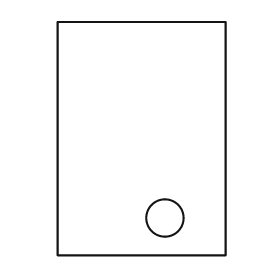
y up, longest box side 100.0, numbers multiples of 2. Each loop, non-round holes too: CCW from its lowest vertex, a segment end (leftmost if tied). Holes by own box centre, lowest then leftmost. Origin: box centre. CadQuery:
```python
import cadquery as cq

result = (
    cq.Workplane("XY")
    .moveTo(-36.0, -50.0)
    .lineTo(36.0, -50.0)
    .lineTo(36.0, 50.0)
    .lineTo(-36.0, 50.0)
    .close()
    .moveTo(10.0, -34.0)
    .circle(8.0)
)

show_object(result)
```